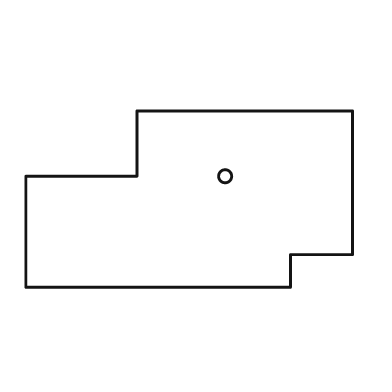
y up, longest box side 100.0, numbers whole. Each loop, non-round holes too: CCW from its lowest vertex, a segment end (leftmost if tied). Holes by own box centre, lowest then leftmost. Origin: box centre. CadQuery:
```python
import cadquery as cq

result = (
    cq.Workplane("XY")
    .moveTo(-50.0, -27.0)
    .lineTo(31.0, -27.0)
    .lineTo(31.0, -17.0)
    .lineTo(50.0, -17.0)
    .lineTo(50.0, 27.0)
    .lineTo(-16.0, 27.0)
    .lineTo(-16.0, 7.0)
    .lineTo(-50.0, 7.0)
    .close()
    .moveTo(11.0, 7.0)
    .circle(2.0)
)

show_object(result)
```